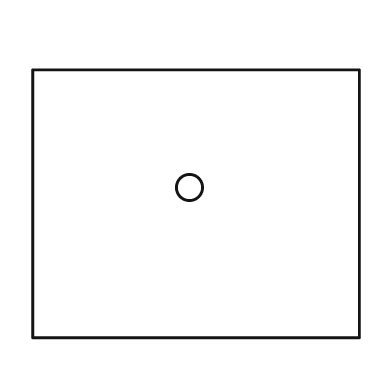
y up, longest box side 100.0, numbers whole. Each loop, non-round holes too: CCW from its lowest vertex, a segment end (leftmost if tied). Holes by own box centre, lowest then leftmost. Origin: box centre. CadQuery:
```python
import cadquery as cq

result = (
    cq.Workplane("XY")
    .moveTo(-50.0, -41.0)
    .lineTo(50.0, -41.0)
    .lineTo(50.0, 41.0)
    .lineTo(-50.0, 41.0)
    .close()
    .moveTo(-2.0, 5.0)
    .circle(4.0)
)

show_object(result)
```